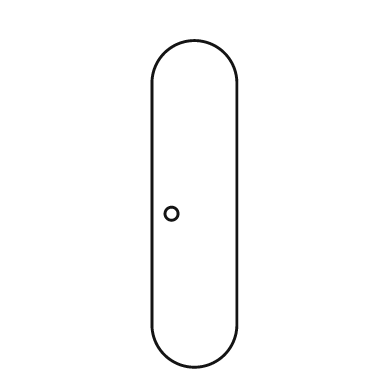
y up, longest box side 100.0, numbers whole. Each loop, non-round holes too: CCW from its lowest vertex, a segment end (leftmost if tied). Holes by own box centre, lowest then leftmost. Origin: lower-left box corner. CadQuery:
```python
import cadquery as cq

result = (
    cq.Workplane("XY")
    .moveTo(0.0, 13.0)
    .threePointArc((13.0, 0.0), (26.0, 13.0))
    .lineTo(26.0, 87.0)
    .threePointArc((13.0, 100.0), (0.0, 87.0))
    .close()
    .moveTo(6.0, 47.0)
    .circle(2.0)
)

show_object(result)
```